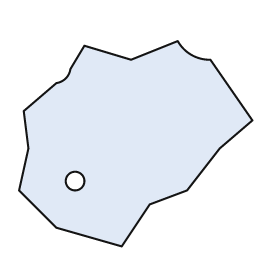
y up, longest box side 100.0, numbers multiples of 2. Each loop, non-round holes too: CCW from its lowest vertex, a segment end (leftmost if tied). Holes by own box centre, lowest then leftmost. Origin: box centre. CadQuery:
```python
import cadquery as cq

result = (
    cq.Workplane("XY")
    .moveTo(-6.0, -44.0)
    .lineTo(6.0, -26.0)
    .lineTo(22.0, -20.0)
    .lineTo(36.0, -2.0)
    .lineTo(50.0, 10.0)
    .lineTo(32.0, 36.0)
    .threePointArc((24.0, 38.0), (18.0, 44.0))
    .lineTo(-2.0, 36.0)
    .lineTo(-22.0, 42.0)
    .lineTo(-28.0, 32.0)
    .threePointArc((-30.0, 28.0), (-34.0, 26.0))
    .lineTo(-48.0, 14.0)
    .lineTo(-46.0, -2.0)
    .lineTo(-50.0, -20.0)
    .lineTo(-34.0, -36.0)
    .close()
    .moveTo(-26.0, -16.0)
    .circle(4.0)
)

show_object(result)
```